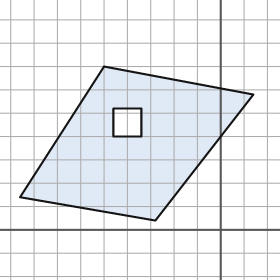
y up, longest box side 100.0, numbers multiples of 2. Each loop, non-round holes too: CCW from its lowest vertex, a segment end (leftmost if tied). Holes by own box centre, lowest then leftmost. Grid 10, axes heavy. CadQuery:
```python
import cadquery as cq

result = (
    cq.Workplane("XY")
    .moveTo(-28.0, 4.0)
    .lineTo(14.0, 58.0)
    .lineTo(-50.0, 70.0)
    .lineTo(-86.0, 14.0)
    .close()
    .moveTo(-46.0, 40.0)
    .lineTo(-34.0, 40.0)
    .lineTo(-34.0, 52.0)
    .lineTo(-46.0, 52.0)
    .close()
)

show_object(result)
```